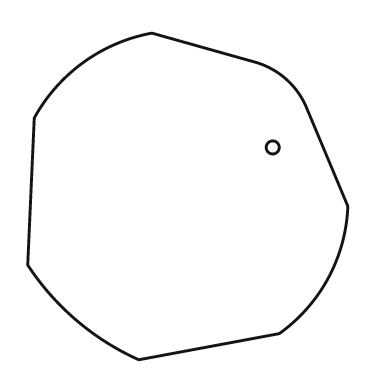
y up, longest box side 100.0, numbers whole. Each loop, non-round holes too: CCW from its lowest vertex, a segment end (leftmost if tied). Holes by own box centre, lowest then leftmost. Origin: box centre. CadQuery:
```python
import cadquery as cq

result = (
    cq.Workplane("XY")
    .moveTo(-15.0, -50.0)
    .lineTo(28.0, -42.0)
    .threePointArc((43.0, -25.0), (49.0, -3.0))
    .lineTo(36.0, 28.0)
    .threePointArc((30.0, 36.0), (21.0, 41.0))
    .lineTo(-11.0, 50.0)
    .threePointArc((-32.0, 41.0), (-47.0, 24.0))
    .lineTo(-49.0, -21.0)
    .threePointArc((-34.0, -38.0), (-15.0, -50.0))
    .close()
    .moveTo(26.0, 15.0)
    .circle(2.0)
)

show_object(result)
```